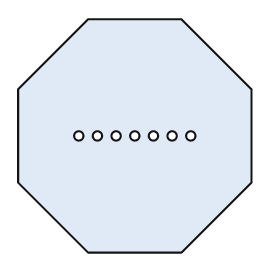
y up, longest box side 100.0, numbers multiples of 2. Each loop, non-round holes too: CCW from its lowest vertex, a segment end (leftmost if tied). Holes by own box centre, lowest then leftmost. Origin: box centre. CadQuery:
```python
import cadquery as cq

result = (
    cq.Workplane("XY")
    .moveTo(-20.0, -50.0)
    .lineTo(20.0, -50.0)
    .lineTo(50.0, -20.0)
    .lineTo(50.0, 20.0)
    .lineTo(20.0, 50.0)
    .lineTo(-20.0, 50.0)
    .lineTo(-50.0, 20.0)
    .lineTo(-50.0, -20.0)
    .close()
    .moveTo(-24.0, 0.0)
    .circle(2.0)
    .moveTo(-16.0, 0.0)
    .circle(2.0)
    .moveTo(-8.0, 0.0)
    .circle(2.0)
    .moveTo(0.0, 0.0)
    .circle(2.0)
    .moveTo(8.0, 0.0)
    .circle(2.0)
    .moveTo(16.0, 0.0)
    .circle(2.0)
    .moveTo(24.0, 0.0)
    .circle(2.0)
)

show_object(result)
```